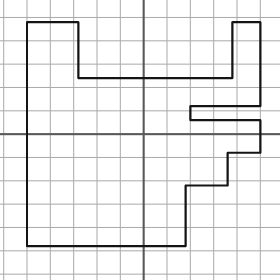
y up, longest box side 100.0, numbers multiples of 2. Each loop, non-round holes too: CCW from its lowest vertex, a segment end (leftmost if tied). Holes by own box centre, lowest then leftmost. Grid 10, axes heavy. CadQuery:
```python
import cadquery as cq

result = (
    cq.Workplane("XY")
    .moveTo(-50.0, -48.0)
    .lineTo(18.0, -48.0)
    .lineTo(18.0, -22.0)
    .lineTo(36.0, -22.0)
    .lineTo(36.0, -8.0)
    .lineTo(50.0, -8.0)
    .lineTo(50.0, 6.0)
    .lineTo(20.0, 6.0)
    .lineTo(20.0, 12.0)
    .lineTo(50.0, 12.0)
    .lineTo(50.0, 48.0)
    .lineTo(38.0, 48.0)
    .lineTo(38.0, 24.0)
    .lineTo(-28.0, 24.0)
    .lineTo(-28.0, 48.0)
    .lineTo(-50.0, 48.0)
    .close()
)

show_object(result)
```